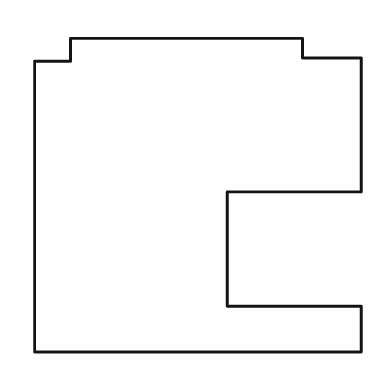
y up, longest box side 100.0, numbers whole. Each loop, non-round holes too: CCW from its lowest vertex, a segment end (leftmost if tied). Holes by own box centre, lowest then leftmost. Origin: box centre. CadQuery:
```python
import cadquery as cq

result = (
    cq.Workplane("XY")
    .moveTo(-50.0, -48.0)
    .lineTo(50.0, -48.0)
    .lineTo(50.0, -34.0)
    .lineTo(9.0, -34.0)
    .lineTo(9.0, 1.0)
    .lineTo(50.0, 1.0)
    .lineTo(50.0, 42.0)
    .lineTo(32.0, 42.0)
    .lineTo(32.0, 48.0)
    .lineTo(-39.0, 48.0)
    .lineTo(-39.0, 41.0)
    .lineTo(-50.0, 41.0)
    .close()
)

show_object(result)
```